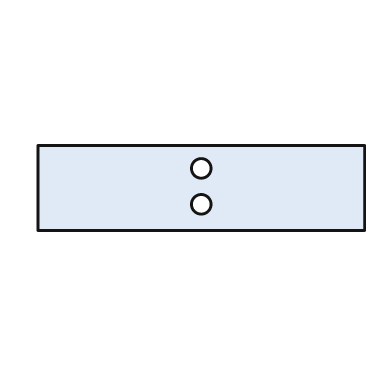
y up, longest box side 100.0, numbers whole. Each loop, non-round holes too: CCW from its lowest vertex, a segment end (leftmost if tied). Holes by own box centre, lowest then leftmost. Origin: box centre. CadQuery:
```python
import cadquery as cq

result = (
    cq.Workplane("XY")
    .moveTo(-50.0, -13.0)
    .lineTo(50.0, -13.0)
    .lineTo(50.0, 13.0)
    .lineTo(-50.0, 13.0)
    .close()
    .moveTo(0.0, -5.0)
    .circle(3.0)
    .moveTo(0.0, 6.0)
    .circle(3.0)
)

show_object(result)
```